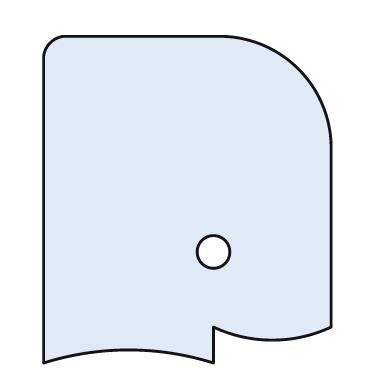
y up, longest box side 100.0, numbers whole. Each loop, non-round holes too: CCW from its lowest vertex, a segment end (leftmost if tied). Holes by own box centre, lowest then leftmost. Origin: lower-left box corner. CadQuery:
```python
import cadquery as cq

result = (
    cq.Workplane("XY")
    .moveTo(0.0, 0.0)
    .threePointArc((26.0, 4.0), (52.0, 0.0))
    .lineTo(52.0, 11.0)
    .threePointArc((70.0, 7.0), (88.0, 11.0))
    .lineTo(88.0, 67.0)
    .threePointArc((78.0, 90.0), (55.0, 100.0))
    .lineTo(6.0, 100.0)
    .threePointArc((2.0, 98.0), (0.0, 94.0))
    .close()
    .moveTo(52.0, 34.0)
    .circle(5.0)
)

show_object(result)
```